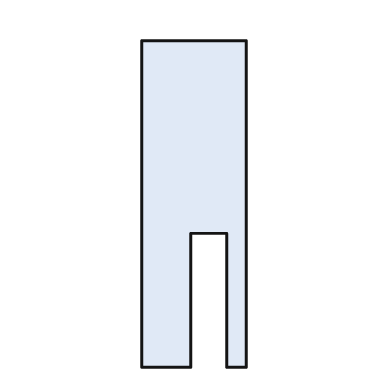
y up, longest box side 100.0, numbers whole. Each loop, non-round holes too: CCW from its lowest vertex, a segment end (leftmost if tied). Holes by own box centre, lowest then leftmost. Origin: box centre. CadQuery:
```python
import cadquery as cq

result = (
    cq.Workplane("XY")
    .moveTo(-16.0, -50.0)
    .lineTo(-1.0, -50.0)
    .lineTo(-1.0, -9.0)
    .lineTo(10.0, -9.0)
    .lineTo(10.0, -50.0)
    .lineTo(16.0, -50.0)
    .lineTo(16.0, 50.0)
    .lineTo(-16.0, 50.0)
    .close()
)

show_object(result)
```